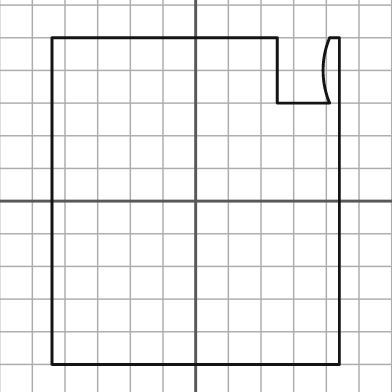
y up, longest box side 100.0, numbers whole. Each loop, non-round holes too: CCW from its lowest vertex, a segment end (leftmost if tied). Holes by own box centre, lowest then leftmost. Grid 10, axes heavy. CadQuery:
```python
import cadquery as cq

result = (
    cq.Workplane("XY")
    .moveTo(-44.0, -50.0)
    .lineTo(44.0, -50.0)
    .lineTo(44.0, 50.0)
    .lineTo(41.0, 50.0)
    .threePointArc((39.0, 40.0), (41.0, 30.0))
    .lineTo(25.0, 30.0)
    .lineTo(25.0, 50.0)
    .lineTo(-44.0, 50.0)
    .close()
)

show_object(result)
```